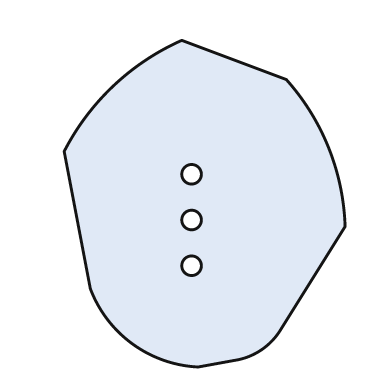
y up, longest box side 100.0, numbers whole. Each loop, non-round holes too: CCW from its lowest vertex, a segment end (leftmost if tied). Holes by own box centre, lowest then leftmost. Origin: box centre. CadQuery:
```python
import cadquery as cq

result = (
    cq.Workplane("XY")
    .moveTo(-2.0, -50.0)
    .lineTo(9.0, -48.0)
    .threePointArc((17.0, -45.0), (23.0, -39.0))
    .lineTo(43.0, -7.0)
    .threePointArc((38.0, 17.0), (25.0, 38.0))
    .lineTo(-7.0, 50.0)
    .threePointArc((-28.0, 36.0), (-43.0, 16.0))
    .lineTo(-35.0, -26.0)
    .threePointArc((-22.0, -43.0), (-2.0, -50.0))
    .close()
    .moveTo(-4.0, -19.0)
    .circle(3.0)
    .moveTo(-4.0, -5.0)
    .circle(3.0)
    .moveTo(-4.0, 9.0)
    .circle(3.0)
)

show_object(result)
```